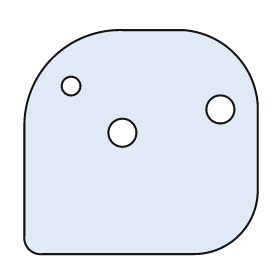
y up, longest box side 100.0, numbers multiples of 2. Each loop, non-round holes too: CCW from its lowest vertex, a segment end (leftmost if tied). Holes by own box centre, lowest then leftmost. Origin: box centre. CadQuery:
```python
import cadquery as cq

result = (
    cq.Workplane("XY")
    .moveTo(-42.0, -48.0)
    .lineTo(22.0, -48.0)
    .threePointArc((42.0, -40.0), (50.0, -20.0))
    .lineTo(50.0, 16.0)
    .threePointArc((40.0, 38.0), (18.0, 48.0))
    .lineTo(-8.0, 48.0)
    .threePointArc((-38.0, 36.0), (-50.0, 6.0))
    .lineTo(-50.0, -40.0)
    .threePointArc((-48.0, -46.0), (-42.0, -48.0))
    .close()
    .moveTo(-8.0, 4.0)
    .circle(6.0)
    .moveTo(34.0, 14.0)
    .circle(6.0)
    .moveTo(-30.0, 24.0)
    .circle(4.0)
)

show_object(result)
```